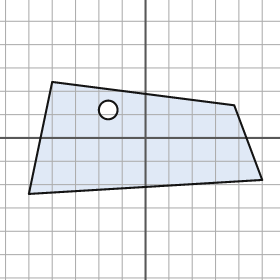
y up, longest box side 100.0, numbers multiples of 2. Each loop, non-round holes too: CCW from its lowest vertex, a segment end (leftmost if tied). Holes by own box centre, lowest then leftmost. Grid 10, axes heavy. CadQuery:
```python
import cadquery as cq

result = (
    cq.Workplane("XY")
    .moveTo(-50.0, -24.0)
    .lineTo(50.0, -18.0)
    .lineTo(38.0, 14.0)
    .lineTo(-40.0, 24.0)
    .close()
    .moveTo(-16.0, 12.0)
    .circle(4.0)
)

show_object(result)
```